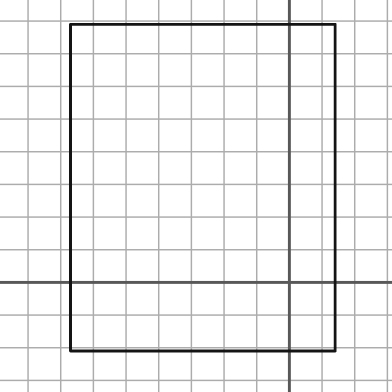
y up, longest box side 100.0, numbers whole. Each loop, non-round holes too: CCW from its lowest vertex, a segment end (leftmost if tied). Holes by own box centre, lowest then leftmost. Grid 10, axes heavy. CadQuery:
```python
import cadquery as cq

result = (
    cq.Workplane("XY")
    .moveTo(-67.0, -21.0)
    .lineTo(14.0, -21.0)
    .lineTo(14.0, 79.0)
    .lineTo(-67.0, 79.0)
    .close()
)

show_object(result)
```